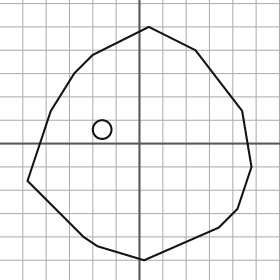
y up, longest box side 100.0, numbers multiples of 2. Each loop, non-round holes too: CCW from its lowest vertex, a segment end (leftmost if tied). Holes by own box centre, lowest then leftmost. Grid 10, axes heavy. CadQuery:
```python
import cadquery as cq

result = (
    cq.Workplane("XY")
    .moveTo(2.0, -50.0)
    .lineTo(34.0, -36.0)
    .lineTo(42.0, -28.0)
    .lineTo(48.0, -10.0)
    .lineTo(44.0, 14.0)
    .lineTo(24.0, 40.0)
    .lineTo(4.0, 50.0)
    .lineTo(-20.0, 38.0)
    .lineTo(-28.0, 30.0)
    .lineTo(-38.0, 14.0)
    .lineTo(-48.0, -16.0)
    .lineTo(-24.0, -40.0)
    .lineTo(-18.0, -44.0)
    .close()
    .moveTo(-16.0, 6.0)
    .circle(4.0)
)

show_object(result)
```